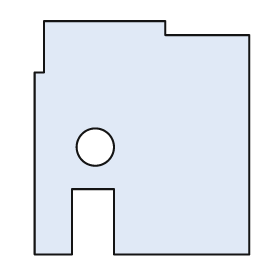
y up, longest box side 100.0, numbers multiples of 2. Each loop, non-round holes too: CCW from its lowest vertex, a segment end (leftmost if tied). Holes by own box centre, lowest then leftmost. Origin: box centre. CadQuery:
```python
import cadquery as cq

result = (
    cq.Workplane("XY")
    .moveTo(-46.0, -50.0)
    .lineTo(-30.0, -50.0)
    .lineTo(-30.0, -22.0)
    .lineTo(-12.0, -22.0)
    .lineTo(-12.0, -50.0)
    .lineTo(46.0, -50.0)
    .lineTo(46.0, 44.0)
    .lineTo(10.0, 44.0)
    .lineTo(10.0, 50.0)
    .lineTo(-42.0, 50.0)
    .lineTo(-42.0, 28.0)
    .lineTo(-46.0, 28.0)
    .close()
    .moveTo(-20.0, -4.0)
    .circle(8.0)
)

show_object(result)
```